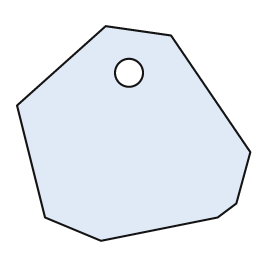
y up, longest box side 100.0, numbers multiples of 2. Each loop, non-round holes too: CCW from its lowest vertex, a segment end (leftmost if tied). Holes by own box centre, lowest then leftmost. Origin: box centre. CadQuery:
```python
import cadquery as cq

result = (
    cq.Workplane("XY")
    .moveTo(-14.0, -46.0)
    .lineTo(36.0, -36.0)
    .lineTo(44.0, -30.0)
    .lineTo(50.0, -8.0)
    .lineTo(16.0, 42.0)
    .lineTo(-12.0, 46.0)
    .lineTo(-50.0, 12.0)
    .lineTo(-38.0, -36.0)
    .close()
    .moveTo(-2.0, 26.0)
    .circle(6.0)
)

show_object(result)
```